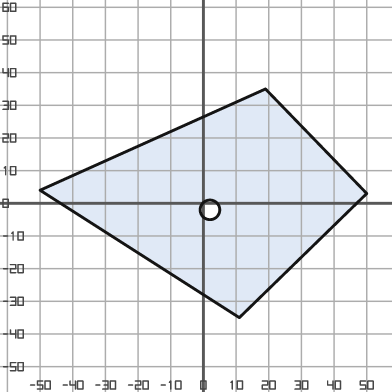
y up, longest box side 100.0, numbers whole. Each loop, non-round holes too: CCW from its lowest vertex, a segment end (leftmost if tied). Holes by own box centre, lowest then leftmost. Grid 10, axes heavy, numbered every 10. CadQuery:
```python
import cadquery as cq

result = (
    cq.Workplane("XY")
    .moveTo(11.0, -35.0)
    .lineTo(50.0, 3.0)
    .lineTo(19.0, 35.0)
    .lineTo(-50.0, 4.0)
    .close()
    .moveTo(2.0, -2.0)
    .circle(3.0)
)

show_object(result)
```